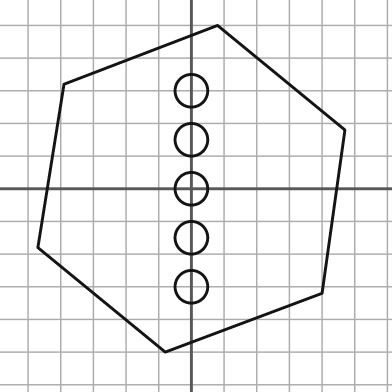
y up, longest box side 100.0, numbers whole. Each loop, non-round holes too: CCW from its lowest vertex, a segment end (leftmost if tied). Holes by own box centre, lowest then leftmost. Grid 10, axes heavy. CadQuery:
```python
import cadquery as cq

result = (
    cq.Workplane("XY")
    .moveTo(-8.0, -50.0)
    .lineTo(40.0, -32.0)
    .lineTo(47.0, 18.0)
    .lineTo(8.0, 50.0)
    .lineTo(-39.0, 32.0)
    .lineTo(-47.0, -18.0)
    .close()
    .moveTo(0.0, -30.0)
    .circle(5.0)
    .moveTo(0.0, -15.0)
    .circle(5.0)
    .moveTo(0.0, 0.0)
    .circle(5.0)
    .moveTo(0.0, 15.0)
    .circle(5.0)
    .moveTo(0.0, 30.0)
    .circle(5.0)
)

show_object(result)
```